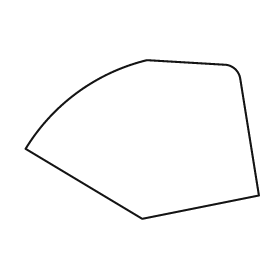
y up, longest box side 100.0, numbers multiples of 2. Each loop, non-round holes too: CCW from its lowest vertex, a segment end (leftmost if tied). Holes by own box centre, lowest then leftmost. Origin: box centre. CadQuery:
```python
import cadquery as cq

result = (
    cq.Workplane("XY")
    .moveTo(0.0, -34.0)
    .lineTo(50.0, -24.0)
    .lineTo(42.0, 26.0)
    .threePointArc((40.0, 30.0), (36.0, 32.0))
    .lineTo(2.0, 34.0)
    .threePointArc((-28.0, 20.0), (-50.0, -4.0))
    .close()
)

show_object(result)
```